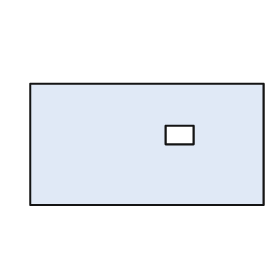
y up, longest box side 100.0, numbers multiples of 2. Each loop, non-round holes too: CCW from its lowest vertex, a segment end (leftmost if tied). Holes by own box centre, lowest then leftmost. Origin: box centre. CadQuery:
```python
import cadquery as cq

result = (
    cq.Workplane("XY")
    .moveTo(-50.0, -26.0)
    .lineTo(50.0, -26.0)
    .lineTo(50.0, 26.0)
    .lineTo(-50.0, 26.0)
    .close()
    .moveTo(8.0, 0.0)
    .lineTo(20.0, 0.0)
    .lineTo(20.0, 8.0)
    .lineTo(8.0, 8.0)
    .close()
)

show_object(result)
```